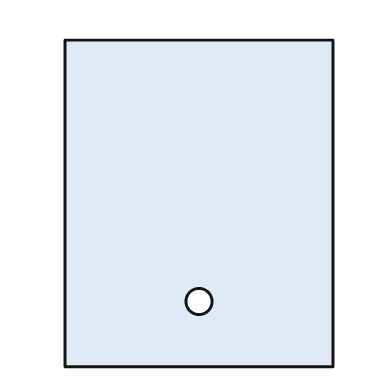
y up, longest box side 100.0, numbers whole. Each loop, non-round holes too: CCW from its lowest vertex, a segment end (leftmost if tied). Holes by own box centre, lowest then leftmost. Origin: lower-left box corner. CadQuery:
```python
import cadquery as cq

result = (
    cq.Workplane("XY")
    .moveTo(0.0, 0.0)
    .lineTo(82.0, 0.0)
    .lineTo(82.0, 100.0)
    .lineTo(0.0, 100.0)
    .close()
    .moveTo(41.0, 20.0)
    .circle(4.0)
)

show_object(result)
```